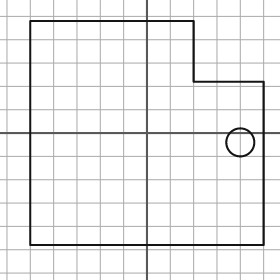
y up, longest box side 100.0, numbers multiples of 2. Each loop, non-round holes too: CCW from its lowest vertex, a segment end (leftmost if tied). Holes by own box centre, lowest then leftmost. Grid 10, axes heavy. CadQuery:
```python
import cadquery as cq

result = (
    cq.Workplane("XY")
    .moveTo(-50.0, -48.0)
    .lineTo(50.0, -48.0)
    .lineTo(50.0, 22.0)
    .lineTo(20.0, 22.0)
    .lineTo(20.0, 48.0)
    .lineTo(-50.0, 48.0)
    .close()
    .moveTo(40.0, -4.0)
    .circle(6.0)
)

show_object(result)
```